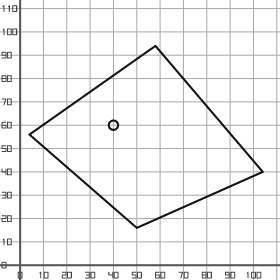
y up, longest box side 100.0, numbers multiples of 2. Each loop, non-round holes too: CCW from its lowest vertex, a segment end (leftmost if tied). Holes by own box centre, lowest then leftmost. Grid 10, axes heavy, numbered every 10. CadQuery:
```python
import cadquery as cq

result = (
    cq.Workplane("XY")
    .moveTo(50.0, 16.0)
    .lineTo(104.0, 40.0)
    .lineTo(58.0, 94.0)
    .lineTo(4.0, 56.0)
    .close()
    .moveTo(40.0, 60.0)
    .circle(2.0)
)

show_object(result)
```